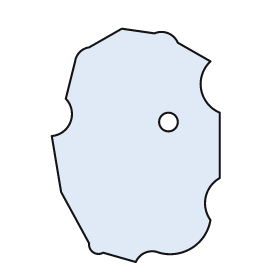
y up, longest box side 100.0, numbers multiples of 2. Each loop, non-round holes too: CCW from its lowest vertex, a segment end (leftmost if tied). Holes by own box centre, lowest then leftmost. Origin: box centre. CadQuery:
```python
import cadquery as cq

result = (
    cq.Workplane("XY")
    .moveTo(0.0, -50.0)
    .threePointArc((4.0, -46.0), (10.0, -46.0))
    .threePointArc((24.0, -44.0), (32.0, -32.0))
    .threePointArc((30.0, -22.0), (36.0, -14.0))
    .lineTo(36.0, 14.0)
    .threePointArc((28.0, 24.0), (32.0, 36.0))
    .lineTo(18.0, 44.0)
    .threePointArc((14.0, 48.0), (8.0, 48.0))
    .lineTo(-6.0, 50.0)
    .lineTo(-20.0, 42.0)
    .threePointArc((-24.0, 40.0), (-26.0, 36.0))
    .lineTo(-30.0, 20.0)
    .threePointArc((-28.0, 10.0), (-36.0, 4.0))
    .lineTo(-32.0, -20.0)
    .lineTo(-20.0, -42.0)
    .threePointArc((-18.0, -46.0), (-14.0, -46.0))
    .close()
    .moveTo(14.0, 10.0)
    .circle(4.0)
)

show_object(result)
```